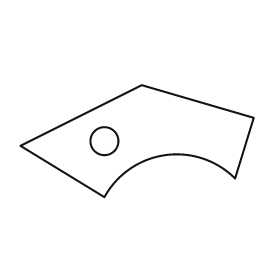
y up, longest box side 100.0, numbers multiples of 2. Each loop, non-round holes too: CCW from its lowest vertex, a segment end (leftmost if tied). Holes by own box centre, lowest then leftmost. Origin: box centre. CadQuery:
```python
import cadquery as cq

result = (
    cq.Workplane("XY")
    .moveTo(-14.0, -24.0)
    .threePointArc((12.0, -6.0), (42.0, -16.0))
    .lineTo(50.0, 10.0)
    .lineTo(2.0, 24.0)
    .lineTo(-50.0, -2.0)
    .close()
    .moveTo(-14.0, 0.0)
    .circle(6.0)
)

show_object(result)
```